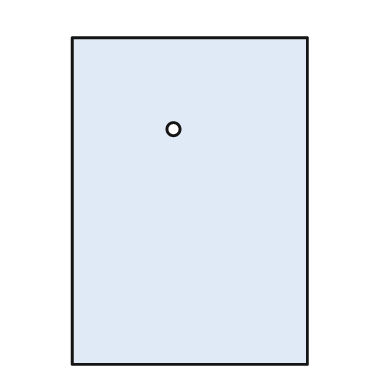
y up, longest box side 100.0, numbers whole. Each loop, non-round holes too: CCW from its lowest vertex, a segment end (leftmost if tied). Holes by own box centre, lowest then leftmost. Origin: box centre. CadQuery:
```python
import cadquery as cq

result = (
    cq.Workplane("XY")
    .moveTo(-36.0, -50.0)
    .lineTo(36.0, -50.0)
    .lineTo(36.0, 50.0)
    .lineTo(-36.0, 50.0)
    .close()
    .moveTo(-5.0, 22.0)
    .circle(2.0)
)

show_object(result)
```